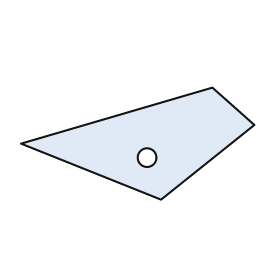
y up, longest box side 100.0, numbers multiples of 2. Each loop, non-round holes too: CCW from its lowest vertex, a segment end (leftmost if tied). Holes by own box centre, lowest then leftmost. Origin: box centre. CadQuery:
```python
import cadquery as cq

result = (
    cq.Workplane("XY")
    .moveTo(10.0, -24.0)
    .lineTo(50.0, 8.0)
    .lineTo(32.0, 24.0)
    .lineTo(-50.0, 0.0)
    .close()
    .moveTo(4.0, -6.0)
    .circle(4.0)
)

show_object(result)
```